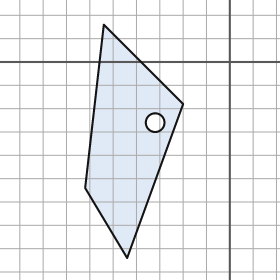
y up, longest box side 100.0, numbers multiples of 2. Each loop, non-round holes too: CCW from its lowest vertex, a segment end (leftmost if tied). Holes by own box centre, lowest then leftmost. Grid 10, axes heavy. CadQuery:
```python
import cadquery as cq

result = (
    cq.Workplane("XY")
    .moveTo(-44.0, -84.0)
    .lineTo(-20.0, -18.0)
    .lineTo(-54.0, 16.0)
    .lineTo(-62.0, -54.0)
    .close()
    .moveTo(-32.0, -26.0)
    .circle(4.0)
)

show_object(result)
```